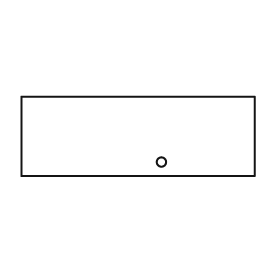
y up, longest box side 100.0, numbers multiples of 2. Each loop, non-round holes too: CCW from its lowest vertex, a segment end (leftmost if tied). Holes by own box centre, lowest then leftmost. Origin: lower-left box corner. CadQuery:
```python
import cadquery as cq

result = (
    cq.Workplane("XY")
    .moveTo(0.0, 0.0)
    .lineTo(100.0, 0.0)
    .lineTo(100.0, 34.0)
    .lineTo(0.0, 34.0)
    .close()
    .moveTo(60.0, 6.0)
    .circle(2.0)
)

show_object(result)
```